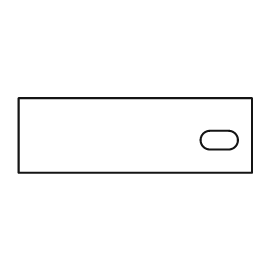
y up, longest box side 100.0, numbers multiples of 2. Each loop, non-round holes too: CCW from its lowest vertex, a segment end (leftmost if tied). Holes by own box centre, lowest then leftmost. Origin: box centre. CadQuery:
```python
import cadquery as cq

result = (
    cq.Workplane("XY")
    .moveTo(-50.0, -16.0)
    .lineTo(50.0, -16.0)
    .lineTo(50.0, 16.0)
    .lineTo(-50.0, 16.0)
    .close()
    .moveTo(32.0, -6.0)
    .lineTo(40.0, -6.0)
    .threePointArc((44.0, -2.0), (40.0, 2.0))
    .lineTo(32.0, 2.0)
    .threePointArc((28.0, -2.0), (32.0, -6.0))
    .close()
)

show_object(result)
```